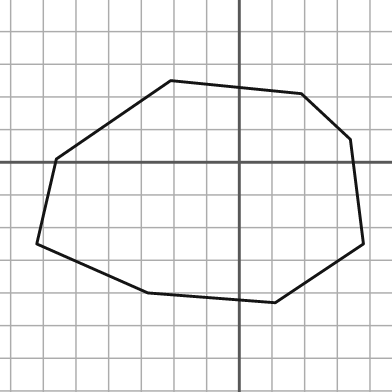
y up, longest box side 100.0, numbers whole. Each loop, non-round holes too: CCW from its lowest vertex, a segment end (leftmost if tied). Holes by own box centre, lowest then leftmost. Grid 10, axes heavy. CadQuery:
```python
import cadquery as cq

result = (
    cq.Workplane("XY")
    .moveTo(11.0, -43.0)
    .lineTo(38.0, -25.0)
    .lineTo(34.0, 7.0)
    .lineTo(19.0, 21.0)
    .lineTo(-21.0, 25.0)
    .lineTo(-56.0, 1.0)
    .lineTo(-62.0, -25.0)
    .lineTo(-28.0, -40.0)
    .close()
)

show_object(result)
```